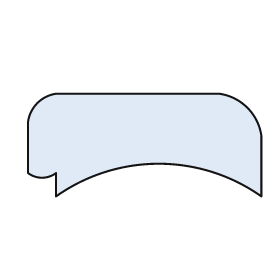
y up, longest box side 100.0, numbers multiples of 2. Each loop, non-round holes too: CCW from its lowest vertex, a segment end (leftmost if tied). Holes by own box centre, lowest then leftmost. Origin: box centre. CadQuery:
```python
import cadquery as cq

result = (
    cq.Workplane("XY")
    .moveTo(-38.0, -22.0)
    .threePointArc((6.0, -8.0), (50.0, -22.0))
    .lineTo(50.0, 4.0)
    .threePointArc((44.0, 16.0), (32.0, 22.0))
    .lineTo(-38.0, 22.0)
    .threePointArc((-46.0, 18.0), (-50.0, 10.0))
    .lineTo(-50.0, -12.0)
    .threePointArc((-44.0, -14.0), (-38.0, -12.0))
    .close()
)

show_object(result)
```